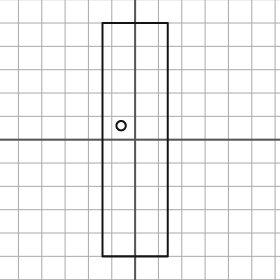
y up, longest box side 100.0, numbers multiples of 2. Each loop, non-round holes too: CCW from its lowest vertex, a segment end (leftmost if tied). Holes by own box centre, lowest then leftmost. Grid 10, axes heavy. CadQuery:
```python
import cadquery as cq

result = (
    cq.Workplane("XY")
    .moveTo(-14.0, -50.0)
    .lineTo(14.0, -50.0)
    .lineTo(14.0, 50.0)
    .lineTo(-14.0, 50.0)
    .close()
    .moveTo(-6.0, 6.0)
    .circle(2.0)
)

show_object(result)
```